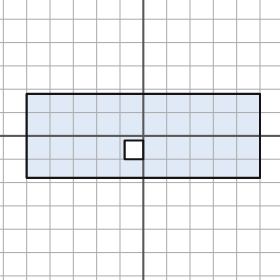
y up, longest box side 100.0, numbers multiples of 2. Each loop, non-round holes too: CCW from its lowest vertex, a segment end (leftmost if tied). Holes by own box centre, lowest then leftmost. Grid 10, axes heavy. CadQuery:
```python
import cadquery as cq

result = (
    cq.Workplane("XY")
    .moveTo(-50.0, -18.0)
    .lineTo(50.0, -18.0)
    .lineTo(50.0, 18.0)
    .lineTo(-50.0, 18.0)
    .close()
    .moveTo(-8.0, -10.0)
    .lineTo(0.0, -10.0)
    .lineTo(0.0, -2.0)
    .lineTo(-8.0, -2.0)
    .close()
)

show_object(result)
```